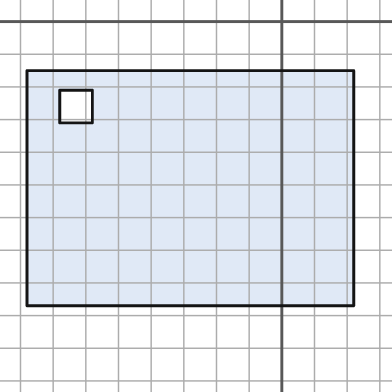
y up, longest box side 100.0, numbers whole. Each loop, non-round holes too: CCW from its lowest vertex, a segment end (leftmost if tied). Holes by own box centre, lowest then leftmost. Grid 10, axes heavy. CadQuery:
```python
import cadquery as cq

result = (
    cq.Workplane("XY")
    .moveTo(-78.0, -87.0)
    .lineTo(22.0, -87.0)
    .lineTo(22.0, -15.0)
    .lineTo(-78.0, -15.0)
    .close()
    .moveTo(-68.0, -31.0)
    .lineTo(-58.0, -31.0)
    .lineTo(-58.0, -21.0)
    .lineTo(-68.0, -21.0)
    .close()
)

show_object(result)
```